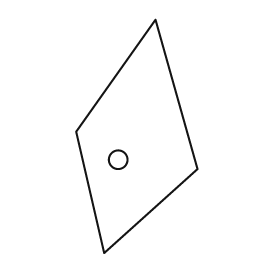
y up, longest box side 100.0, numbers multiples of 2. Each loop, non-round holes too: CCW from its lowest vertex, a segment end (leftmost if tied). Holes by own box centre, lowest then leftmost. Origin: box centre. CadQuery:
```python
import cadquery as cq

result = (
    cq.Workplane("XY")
    .moveTo(-14.0, -50.0)
    .lineTo(26.0, -14.0)
    .lineTo(8.0, 50.0)
    .lineTo(-26.0, 2.0)
    .close()
    .moveTo(-8.0, -10.0)
    .circle(4.0)
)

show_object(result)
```